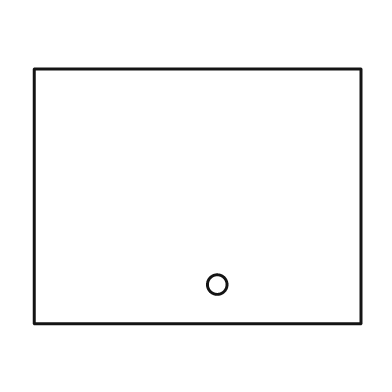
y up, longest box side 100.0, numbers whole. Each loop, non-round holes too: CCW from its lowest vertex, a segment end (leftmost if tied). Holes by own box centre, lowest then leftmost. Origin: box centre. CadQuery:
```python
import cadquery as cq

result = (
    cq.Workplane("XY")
    .moveTo(-50.0, -39.0)
    .lineTo(50.0, -39.0)
    .lineTo(50.0, 39.0)
    .lineTo(-50.0, 39.0)
    .close()
    .moveTo(6.0, -27.0)
    .circle(3.0)
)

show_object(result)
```